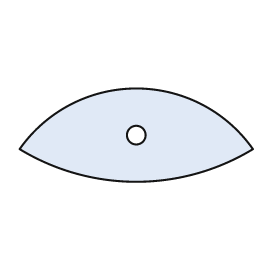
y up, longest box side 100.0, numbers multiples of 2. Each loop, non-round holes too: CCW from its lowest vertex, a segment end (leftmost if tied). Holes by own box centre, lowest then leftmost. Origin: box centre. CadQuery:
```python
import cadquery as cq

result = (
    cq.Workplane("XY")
    .moveTo(-50.0, -6.0)
    .threePointArc((0.0, -20.0), (50.0, -6.0))
    .threePointArc((0.0, 20.0), (-50.0, -6.0))
    .close()
    .moveTo(0.0, 0.0)
    .circle(4.0)
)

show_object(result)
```